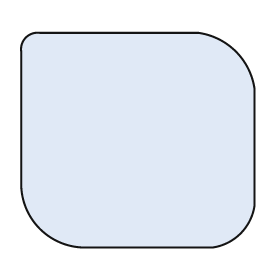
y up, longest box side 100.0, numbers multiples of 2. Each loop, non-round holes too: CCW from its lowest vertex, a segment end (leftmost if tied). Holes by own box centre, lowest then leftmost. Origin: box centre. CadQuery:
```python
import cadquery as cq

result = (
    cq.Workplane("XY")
    .moveTo(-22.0, -46.0)
    .lineTo(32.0, -46.0)
    .threePointArc((44.0, -40.0), (50.0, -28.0))
    .lineTo(50.0, 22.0)
    .threePointArc((42.0, 38.0), (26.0, 46.0))
    .lineTo(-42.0, 46.0)
    .threePointArc((-48.0, 44.0), (-50.0, 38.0))
    .lineTo(-50.0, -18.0)
    .threePointArc((-42.0, -38.0), (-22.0, -46.0))
    .close()
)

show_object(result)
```